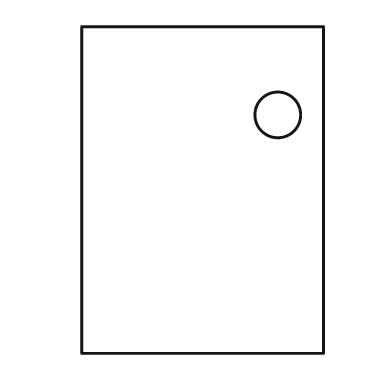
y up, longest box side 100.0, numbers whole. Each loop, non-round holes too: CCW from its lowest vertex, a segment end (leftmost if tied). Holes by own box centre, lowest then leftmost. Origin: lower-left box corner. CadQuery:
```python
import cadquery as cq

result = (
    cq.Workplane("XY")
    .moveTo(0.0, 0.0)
    .lineTo(74.0, 0.0)
    .lineTo(74.0, 100.0)
    .lineTo(0.0, 100.0)
    .close()
    .moveTo(60.0, 73.0)
    .circle(7.0)
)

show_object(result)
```